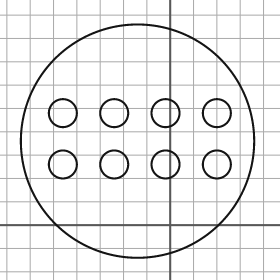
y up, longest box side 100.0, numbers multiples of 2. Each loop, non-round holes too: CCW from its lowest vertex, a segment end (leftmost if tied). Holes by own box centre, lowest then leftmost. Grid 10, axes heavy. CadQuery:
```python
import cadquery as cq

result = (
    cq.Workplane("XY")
    .moveTo(-14.0, 36.0)
    .circle(50.0)
    .moveTo(-46.0, 26.0)
    .circle(6.0)
    .moveTo(-24.0, 26.0)
    .circle(6.0)
    .moveTo(-2.0, 26.0)
    .circle(6.0)
    .moveTo(20.0, 26.0)
    .circle(6.0)
    .moveTo(-46.0, 48.0)
    .circle(6.0)
    .moveTo(-24.0, 48.0)
    .circle(6.0)
    .moveTo(-2.0, 48.0)
    .circle(6.0)
    .moveTo(20.0, 48.0)
    .circle(6.0)
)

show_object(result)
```